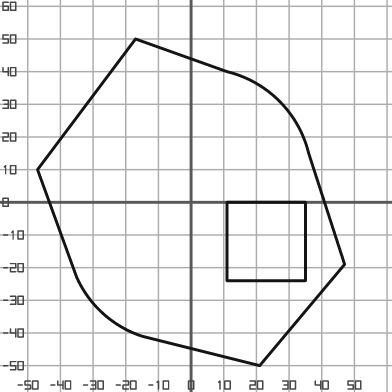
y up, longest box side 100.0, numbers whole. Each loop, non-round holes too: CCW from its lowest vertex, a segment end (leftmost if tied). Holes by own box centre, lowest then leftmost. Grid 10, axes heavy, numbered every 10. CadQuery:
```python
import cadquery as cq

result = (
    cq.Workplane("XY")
    .moveTo(21.0, -50.0)
    .lineTo(47.0, -19.0)
    .lineTo(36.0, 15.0)
    .threePointArc((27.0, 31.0), (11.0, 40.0))
    .lineTo(-17.0, 50.0)
    .lineTo(-47.0, 10.0)
    .lineTo(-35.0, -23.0)
    .threePointArc((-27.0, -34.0), (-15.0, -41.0))
    .close()
    .moveTo(11.0, -24.0)
    .lineTo(35.0, -24.0)
    .lineTo(35.0, 0.0)
    .lineTo(11.0, 0.0)
    .close()
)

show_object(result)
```